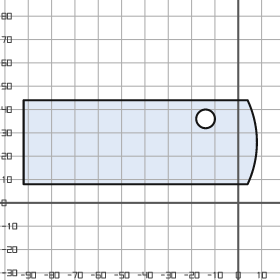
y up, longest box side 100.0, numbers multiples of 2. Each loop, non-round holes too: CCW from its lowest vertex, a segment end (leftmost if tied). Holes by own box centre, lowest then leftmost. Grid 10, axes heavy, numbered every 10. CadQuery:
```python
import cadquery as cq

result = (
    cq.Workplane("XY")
    .moveTo(-92.0, 8.0)
    .lineTo(4.0, 8.0)
    .threePointArc((8.0, 26.0), (4.0, 44.0))
    .lineTo(-92.0, 44.0)
    .close()
    .moveTo(-14.0, 36.0)
    .circle(4.0)
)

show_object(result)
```